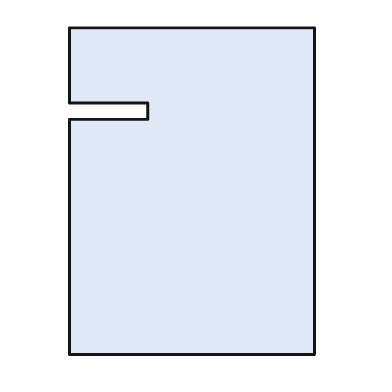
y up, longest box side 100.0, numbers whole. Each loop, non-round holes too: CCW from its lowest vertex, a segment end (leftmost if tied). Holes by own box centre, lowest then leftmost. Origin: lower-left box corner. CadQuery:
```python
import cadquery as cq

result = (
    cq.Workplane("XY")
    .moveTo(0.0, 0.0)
    .lineTo(75.0, 0.0)
    .lineTo(75.0, 100.0)
    .lineTo(0.0, 100.0)
    .lineTo(0.0, 77.0)
    .lineTo(24.0, 77.0)
    .lineTo(24.0, 72.0)
    .lineTo(0.0, 72.0)
    .close()
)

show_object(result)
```